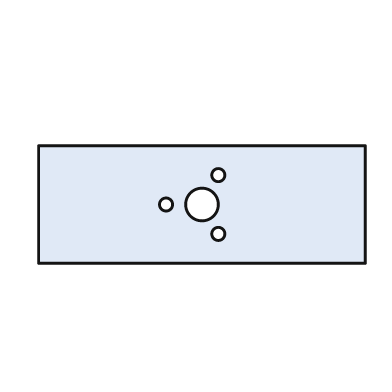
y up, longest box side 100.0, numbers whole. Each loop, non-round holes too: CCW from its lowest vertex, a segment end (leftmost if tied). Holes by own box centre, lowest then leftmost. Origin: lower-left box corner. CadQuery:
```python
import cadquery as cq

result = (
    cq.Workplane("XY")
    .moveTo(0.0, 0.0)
    .lineTo(100.0, 0.0)
    .lineTo(100.0, 36.0)
    .lineTo(0.0, 36.0)
    .close()
    .moveTo(55.0, 9.0)
    .circle(2.0)
    .moveTo(39.0, 18.0)
    .circle(2.0)
    .moveTo(50.0, 18.0)
    .circle(5.0)
    .moveTo(55.0, 27.0)
    .circle(2.0)
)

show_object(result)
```